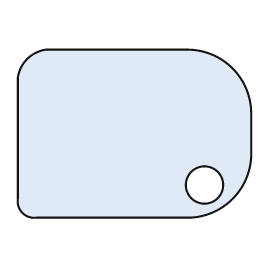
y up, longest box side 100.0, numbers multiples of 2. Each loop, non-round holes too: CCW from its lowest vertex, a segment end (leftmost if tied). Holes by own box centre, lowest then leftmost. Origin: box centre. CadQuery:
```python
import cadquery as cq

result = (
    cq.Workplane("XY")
    .moveTo(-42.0, -36.0)
    .lineTo(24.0, -36.0)
    .threePointArc((42.0, -28.0), (50.0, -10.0))
    .lineTo(50.0, 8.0)
    .threePointArc((42.0, 28.0), (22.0, 36.0))
    .lineTo(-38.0, 36.0)
    .threePointArc((-46.0, 32.0), (-50.0, 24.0))
    .lineTo(-50.0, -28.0)
    .threePointArc((-48.0, -34.0), (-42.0, -36.0))
    .close()
    .moveTo(30.0, -22.0)
    .circle(8.0)
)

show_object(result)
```